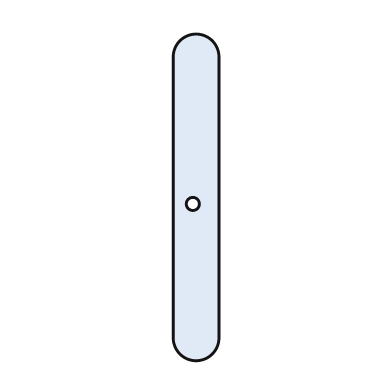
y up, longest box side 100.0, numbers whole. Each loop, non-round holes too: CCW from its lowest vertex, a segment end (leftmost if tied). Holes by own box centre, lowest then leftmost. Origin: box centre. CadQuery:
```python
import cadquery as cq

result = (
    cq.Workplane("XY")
    .moveTo(-7.0, -43.0)
    .threePointArc((0.0, -50.0), (7.0, -43.0))
    .lineTo(7.0, 43.0)
    .threePointArc((0.0, 50.0), (-7.0, 43.0))
    .close()
    .moveTo(-1.0, -2.0)
    .circle(2.0)
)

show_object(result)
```